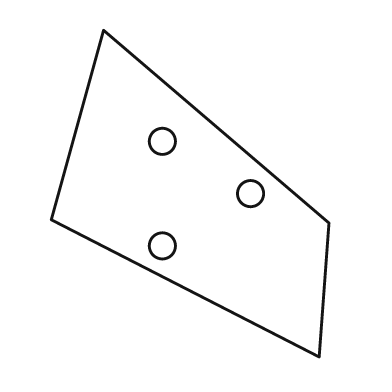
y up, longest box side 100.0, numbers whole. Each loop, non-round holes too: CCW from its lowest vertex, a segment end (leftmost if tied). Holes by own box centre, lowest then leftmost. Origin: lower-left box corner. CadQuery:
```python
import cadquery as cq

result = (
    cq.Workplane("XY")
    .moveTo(82.0, 0.0)
    .lineTo(85.0, 41.0)
    .lineTo(16.0, 100.0)
    .lineTo(0.0, 42.0)
    .close()
    .moveTo(34.0, 34.0)
    .circle(4.0)
    .moveTo(61.0, 50.0)
    .circle(4.0)
    .moveTo(34.0, 66.0)
    .circle(4.0)
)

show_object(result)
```